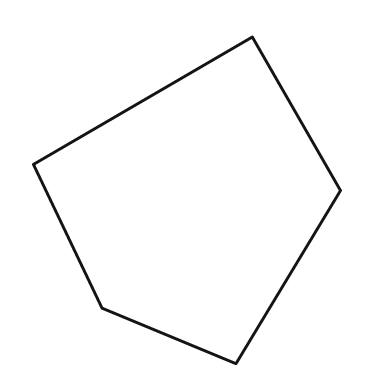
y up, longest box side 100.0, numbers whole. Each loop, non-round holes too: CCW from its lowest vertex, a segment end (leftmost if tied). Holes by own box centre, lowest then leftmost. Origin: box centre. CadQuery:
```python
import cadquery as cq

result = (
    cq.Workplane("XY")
    .moveTo(15.0, -50.0)
    .lineTo(47.0, 3.0)
    .lineTo(20.0, 50.0)
    .lineTo(-47.0, 11.0)
    .lineTo(-26.0, -33.0)
    .close()
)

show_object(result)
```